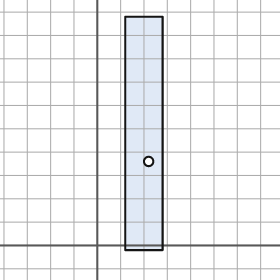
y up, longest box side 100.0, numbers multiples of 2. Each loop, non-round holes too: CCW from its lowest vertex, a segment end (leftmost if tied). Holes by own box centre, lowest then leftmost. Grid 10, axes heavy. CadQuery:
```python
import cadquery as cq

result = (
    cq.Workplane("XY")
    .moveTo(12.0, -2.0)
    .lineTo(28.0, -2.0)
    .lineTo(28.0, 98.0)
    .lineTo(12.0, 98.0)
    .close()
    .moveTo(22.0, 36.0)
    .circle(2.0)
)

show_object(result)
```